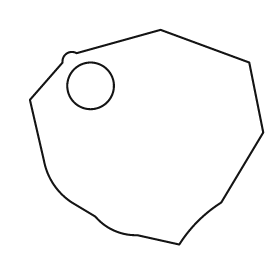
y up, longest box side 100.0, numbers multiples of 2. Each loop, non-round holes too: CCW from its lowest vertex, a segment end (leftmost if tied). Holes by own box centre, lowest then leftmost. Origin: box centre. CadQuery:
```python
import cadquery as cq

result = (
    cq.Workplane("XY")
    .moveTo(14.0, -46.0)
    .threePointArc((22.0, -36.0), (32.0, -28.0))
    .lineTo(50.0, 2.0)
    .lineTo(44.0, 32.0)
    .lineTo(6.0, 46.0)
    .lineTo(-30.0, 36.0)
    .threePointArc((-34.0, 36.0), (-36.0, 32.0))
    .lineTo(-50.0, 16.0)
    .lineTo(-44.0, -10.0)
    .threePointArc((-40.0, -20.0), (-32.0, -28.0))
    .lineTo(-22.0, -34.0)
    .threePointArc((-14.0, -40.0), (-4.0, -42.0))
    .close()
    .moveTo(-24.0, 22.0)
    .circle(10.0)
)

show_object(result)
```